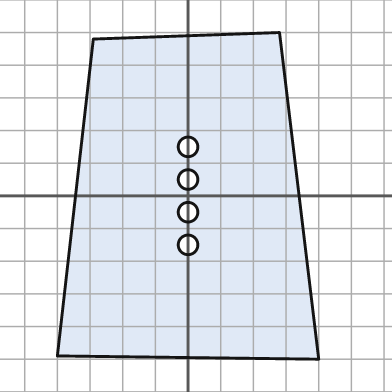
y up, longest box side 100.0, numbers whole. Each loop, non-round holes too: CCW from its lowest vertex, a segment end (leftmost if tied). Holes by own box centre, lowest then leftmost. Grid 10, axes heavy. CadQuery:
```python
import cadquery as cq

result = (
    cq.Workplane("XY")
    .moveTo(40.0, -50.0)
    .lineTo(28.0, 50.0)
    .lineTo(-29.0, 48.0)
    .lineTo(-40.0, -49.0)
    .close()
    .moveTo(0.0, -15.0)
    .circle(3.0)
    .moveTo(0.0, -5.0)
    .circle(3.0)
    .moveTo(0.0, 5.0)
    .circle(3.0)
    .moveTo(0.0, 15.0)
    .circle(3.0)
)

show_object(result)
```